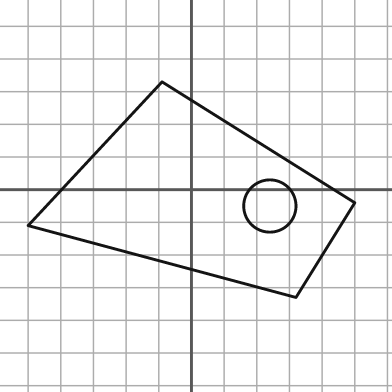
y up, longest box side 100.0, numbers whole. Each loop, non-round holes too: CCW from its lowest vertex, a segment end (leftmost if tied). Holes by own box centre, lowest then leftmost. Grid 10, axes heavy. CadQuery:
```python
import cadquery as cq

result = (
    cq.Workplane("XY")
    .moveTo(32.0, -33.0)
    .lineTo(50.0, -4.0)
    .lineTo(-9.0, 33.0)
    .lineTo(-50.0, -11.0)
    .close()
    .moveTo(24.0, -5.0)
    .circle(8.0)
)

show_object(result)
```